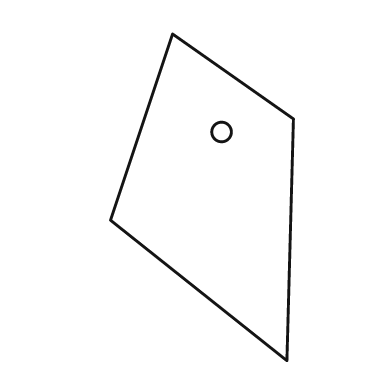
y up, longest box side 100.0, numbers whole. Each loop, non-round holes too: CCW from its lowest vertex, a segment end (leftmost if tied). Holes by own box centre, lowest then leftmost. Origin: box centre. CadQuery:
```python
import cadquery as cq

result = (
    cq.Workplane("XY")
    .moveTo(26.0, -50.0)
    .lineTo(28.0, 24.0)
    .lineTo(-9.0, 50.0)
    .lineTo(-28.0, -7.0)
    .close()
    .moveTo(6.0, 20.0)
    .circle(3.0)
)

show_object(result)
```